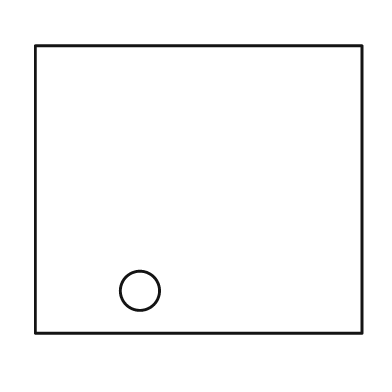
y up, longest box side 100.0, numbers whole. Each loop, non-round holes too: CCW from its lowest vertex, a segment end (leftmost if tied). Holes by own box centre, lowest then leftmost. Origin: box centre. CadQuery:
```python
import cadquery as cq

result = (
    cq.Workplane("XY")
    .moveTo(-50.0, -44.0)
    .lineTo(50.0, -44.0)
    .lineTo(50.0, 44.0)
    .lineTo(-50.0, 44.0)
    .close()
    .moveTo(-18.0, -31.0)
    .circle(6.0)
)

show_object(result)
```